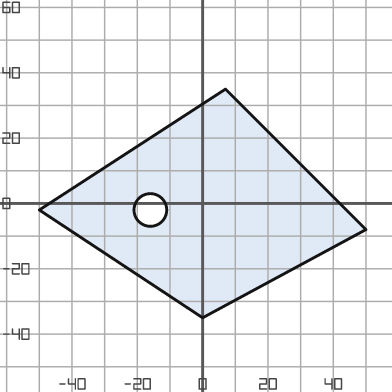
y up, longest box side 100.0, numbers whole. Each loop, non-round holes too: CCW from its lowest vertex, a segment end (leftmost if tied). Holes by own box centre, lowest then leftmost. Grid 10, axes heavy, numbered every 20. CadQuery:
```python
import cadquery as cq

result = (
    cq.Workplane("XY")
    .moveTo(0.0, -35.0)
    .lineTo(50.0, -8.0)
    .lineTo(7.0, 35.0)
    .lineTo(-50.0, -2.0)
    .close()
    .moveTo(-16.0, -2.0)
    .circle(5.0)
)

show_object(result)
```